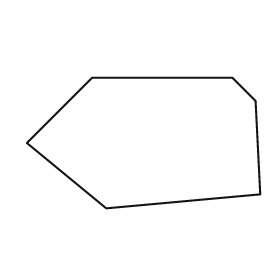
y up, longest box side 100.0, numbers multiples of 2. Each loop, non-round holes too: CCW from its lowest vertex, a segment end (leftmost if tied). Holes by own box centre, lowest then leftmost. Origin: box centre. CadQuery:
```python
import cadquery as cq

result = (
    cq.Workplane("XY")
    .moveTo(-16.0, -28.0)
    .lineTo(50.0, -22.0)
    .lineTo(48.0, 18.0)
    .lineTo(38.0, 28.0)
    .lineTo(-22.0, 28.0)
    .lineTo(-50.0, 0.0)
    .close()
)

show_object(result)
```